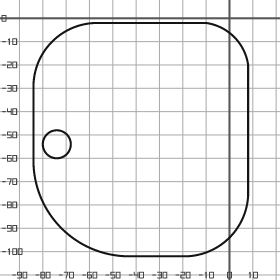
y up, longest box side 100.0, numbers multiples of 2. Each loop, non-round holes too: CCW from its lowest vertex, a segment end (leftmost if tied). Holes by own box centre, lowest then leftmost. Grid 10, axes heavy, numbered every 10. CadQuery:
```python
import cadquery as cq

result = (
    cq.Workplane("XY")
    .moveTo(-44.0, -102.0)
    .lineTo(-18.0, -102.0)
    .threePointArc((0.0, -94.0), (8.0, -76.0))
    .lineTo(8.0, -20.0)
    .threePointArc((2.0, -8.0), (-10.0, -2.0))
    .lineTo(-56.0, -2.0)
    .threePointArc((-76.0, -10.0), (-84.0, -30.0))
    .lineTo(-84.0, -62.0)
    .threePointArc((-72.0, -90.0), (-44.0, -102.0))
    .close()
    .moveTo(-74.0, -54.0)
    .circle(6.0)
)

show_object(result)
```